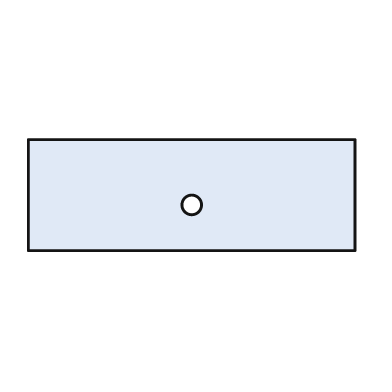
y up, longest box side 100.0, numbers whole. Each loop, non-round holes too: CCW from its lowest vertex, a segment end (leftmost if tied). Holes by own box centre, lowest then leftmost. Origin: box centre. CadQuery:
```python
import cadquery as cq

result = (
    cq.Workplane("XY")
    .moveTo(-50.0, -17.0)
    .lineTo(50.0, -17.0)
    .lineTo(50.0, 17.0)
    .lineTo(-50.0, 17.0)
    .close()
    .moveTo(0.0, -3.0)
    .circle(3.0)
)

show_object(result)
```